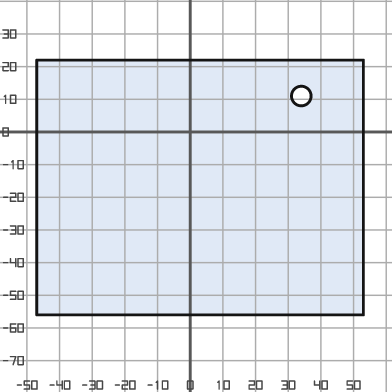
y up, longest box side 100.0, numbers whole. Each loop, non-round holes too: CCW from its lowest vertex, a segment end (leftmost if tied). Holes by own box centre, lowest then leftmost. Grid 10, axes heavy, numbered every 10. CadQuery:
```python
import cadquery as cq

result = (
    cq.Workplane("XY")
    .moveTo(-47.0, -56.0)
    .lineTo(53.0, -56.0)
    .lineTo(53.0, 22.0)
    .lineTo(-47.0, 22.0)
    .close()
    .moveTo(34.0, 11.0)
    .circle(3.0)
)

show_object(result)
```